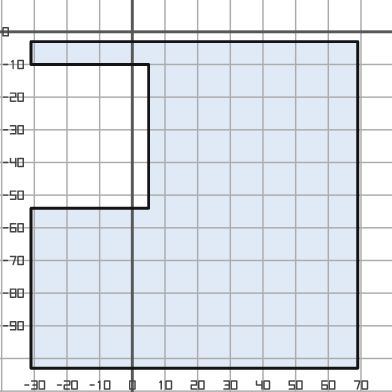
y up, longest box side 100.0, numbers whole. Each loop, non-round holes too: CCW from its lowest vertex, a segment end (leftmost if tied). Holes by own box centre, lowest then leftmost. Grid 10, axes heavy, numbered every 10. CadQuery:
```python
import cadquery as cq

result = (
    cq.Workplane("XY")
    .moveTo(-31.0, -103.0)
    .lineTo(69.0, -103.0)
    .lineTo(69.0, -3.0)
    .lineTo(-31.0, -3.0)
    .lineTo(-31.0, -10.0)
    .lineTo(5.0, -10.0)
    .lineTo(5.0, -54.0)
    .lineTo(-31.0, -54.0)
    .close()
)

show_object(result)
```